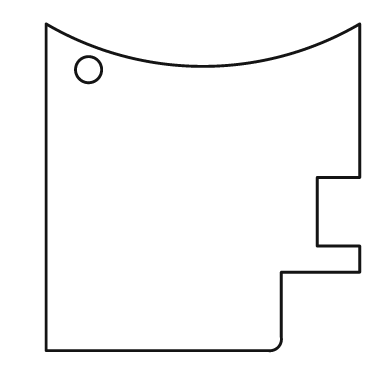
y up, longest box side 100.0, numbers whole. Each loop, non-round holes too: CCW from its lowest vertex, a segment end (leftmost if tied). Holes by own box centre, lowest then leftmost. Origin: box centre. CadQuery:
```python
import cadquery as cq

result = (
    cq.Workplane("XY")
    .moveTo(-48.0, -50.0)
    .lineTo(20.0, -50.0)
    .threePointArc((23.0, -49.0), (24.0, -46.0))
    .lineTo(24.0, -26.0)
    .lineTo(48.0, -26.0)
    .lineTo(48.0, -18.0)
    .lineTo(35.0, -18.0)
    .lineTo(35.0, 3.0)
    .lineTo(48.0, 3.0)
    .lineTo(48.0, 50.0)
    .threePointArc((0.0, 37.0), (-48.0, 50.0))
    .close()
    .moveTo(-35.0, 36.0)
    .circle(4.0)
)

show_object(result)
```